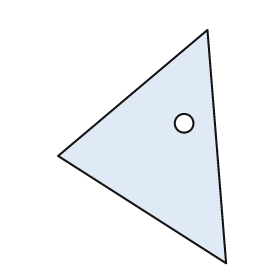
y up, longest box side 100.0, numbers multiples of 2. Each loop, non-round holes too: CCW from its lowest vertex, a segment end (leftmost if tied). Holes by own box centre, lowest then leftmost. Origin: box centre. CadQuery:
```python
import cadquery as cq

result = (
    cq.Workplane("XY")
    .moveTo(36.0, -50.0)
    .lineTo(28.0, 50.0)
    .lineTo(-36.0, -4.0)
    .close()
    .moveTo(18.0, 10.0)
    .circle(4.0)
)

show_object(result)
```